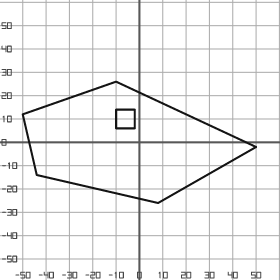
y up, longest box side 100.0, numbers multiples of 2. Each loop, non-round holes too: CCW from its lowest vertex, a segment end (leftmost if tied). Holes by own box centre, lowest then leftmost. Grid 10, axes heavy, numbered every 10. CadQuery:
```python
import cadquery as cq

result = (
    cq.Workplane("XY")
    .moveTo(8.0, -26.0)
    .lineTo(50.0, -2.0)
    .lineTo(-10.0, 26.0)
    .lineTo(-50.0, 12.0)
    .lineTo(-44.0, -14.0)
    .close()
    .moveTo(-10.0, 6.0)
    .lineTo(-2.0, 6.0)
    .lineTo(-2.0, 14.0)
    .lineTo(-10.0, 14.0)
    .close()
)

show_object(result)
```